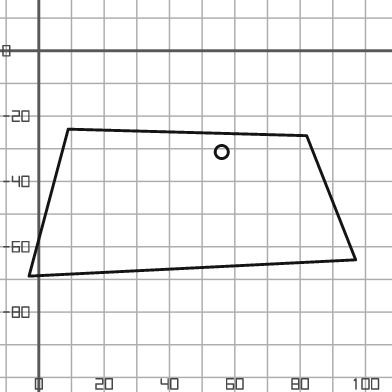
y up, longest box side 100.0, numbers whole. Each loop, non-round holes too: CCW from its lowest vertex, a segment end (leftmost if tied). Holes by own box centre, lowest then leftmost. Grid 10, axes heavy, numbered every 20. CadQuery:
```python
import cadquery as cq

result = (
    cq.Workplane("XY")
    .moveTo(-3.0, -69.0)
    .lineTo(97.0, -64.0)
    .lineTo(82.0, -26.0)
    .lineTo(9.0, -24.0)
    .close()
    .moveTo(56.0, -31.0)
    .circle(2.0)
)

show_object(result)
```